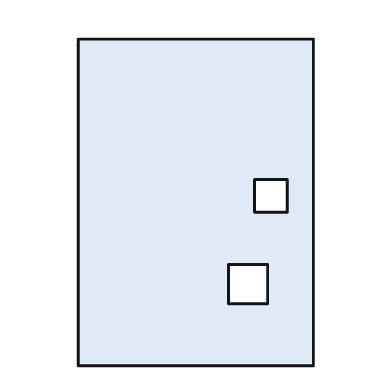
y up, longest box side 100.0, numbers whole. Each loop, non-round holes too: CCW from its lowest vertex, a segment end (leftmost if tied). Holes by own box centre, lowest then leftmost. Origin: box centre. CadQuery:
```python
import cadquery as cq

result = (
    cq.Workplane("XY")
    .moveTo(-36.0, -50.0)
    .lineTo(36.0, -50.0)
    .lineTo(36.0, 50.0)
    .lineTo(-36.0, 50.0)
    .close()
    .moveTo(10.0, -31.0)
    .lineTo(22.0, -31.0)
    .lineTo(22.0, -19.0)
    .lineTo(10.0, -19.0)
    .close()
    .moveTo(18.0, -3.0)
    .lineTo(28.0, -3.0)
    .lineTo(28.0, 7.0)
    .lineTo(18.0, 7.0)
    .close()
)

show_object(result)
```